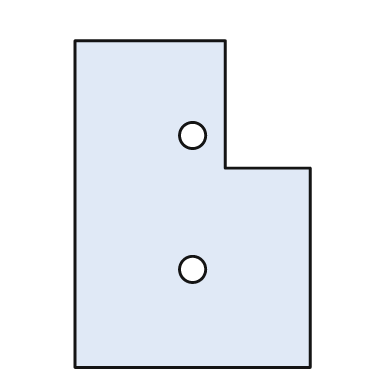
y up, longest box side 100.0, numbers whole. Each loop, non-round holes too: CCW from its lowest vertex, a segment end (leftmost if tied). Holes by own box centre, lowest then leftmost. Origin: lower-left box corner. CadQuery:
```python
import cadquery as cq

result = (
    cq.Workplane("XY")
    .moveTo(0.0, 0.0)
    .lineTo(72.0, 0.0)
    .lineTo(72.0, 61.0)
    .lineTo(46.0, 61.0)
    .lineTo(46.0, 100.0)
    .lineTo(0.0, 100.0)
    .close()
    .moveTo(36.0, 30.0)
    .circle(4.0)
    .moveTo(36.0, 71.0)
    .circle(4.0)
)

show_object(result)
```